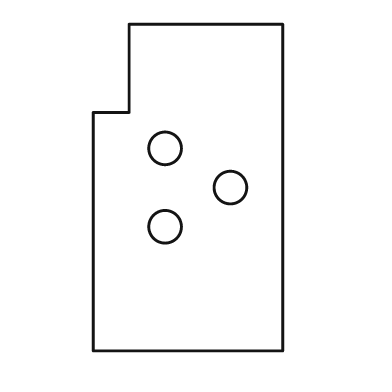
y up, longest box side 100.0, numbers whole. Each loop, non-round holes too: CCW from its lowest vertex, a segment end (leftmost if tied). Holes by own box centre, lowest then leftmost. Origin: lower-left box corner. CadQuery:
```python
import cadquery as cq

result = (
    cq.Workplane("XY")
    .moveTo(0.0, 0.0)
    .lineTo(58.0, 0.0)
    .lineTo(58.0, 100.0)
    .lineTo(11.0, 100.0)
    .lineTo(11.0, 73.0)
    .lineTo(0.0, 73.0)
    .close()
    .moveTo(22.0, 38.0)
    .circle(5.0)
    .moveTo(42.0, 50.0)
    .circle(5.0)
    .moveTo(22.0, 62.0)
    .circle(5.0)
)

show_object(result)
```